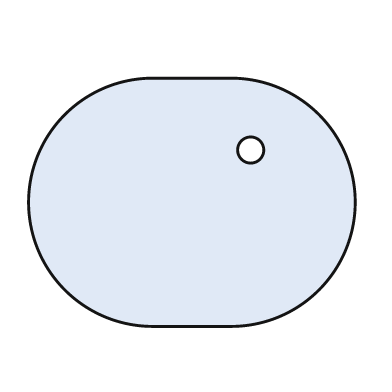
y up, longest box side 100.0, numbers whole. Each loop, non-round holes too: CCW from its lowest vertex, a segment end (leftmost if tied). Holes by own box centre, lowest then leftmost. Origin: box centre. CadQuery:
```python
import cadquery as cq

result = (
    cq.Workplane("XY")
    .moveTo(-12.0, -38.0)
    .lineTo(12.0, -38.0)
    .threePointArc((50.0, 0.0), (12.0, 38.0))
    .lineTo(-12.0, 38.0)
    .threePointArc((-50.0, 0.0), (-12.0, -38.0))
    .close()
    .moveTo(18.0, 16.0)
    .circle(4.0)
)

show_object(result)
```